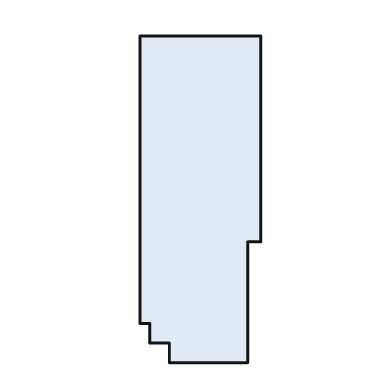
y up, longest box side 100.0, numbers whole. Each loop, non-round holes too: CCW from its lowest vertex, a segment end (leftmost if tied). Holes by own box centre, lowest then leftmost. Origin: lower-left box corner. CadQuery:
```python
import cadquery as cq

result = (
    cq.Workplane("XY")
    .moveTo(9.0, 0.0)
    .lineTo(33.0, 0.0)
    .lineTo(33.0, 37.0)
    .lineTo(37.0, 37.0)
    .lineTo(37.0, 100.0)
    .lineTo(0.0, 100.0)
    .lineTo(0.0, 12.0)
    .lineTo(3.0, 12.0)
    .lineTo(3.0, 6.0)
    .lineTo(9.0, 6.0)
    .close()
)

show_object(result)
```